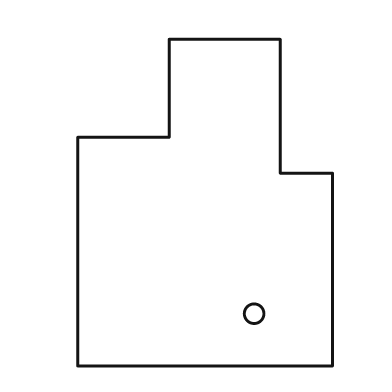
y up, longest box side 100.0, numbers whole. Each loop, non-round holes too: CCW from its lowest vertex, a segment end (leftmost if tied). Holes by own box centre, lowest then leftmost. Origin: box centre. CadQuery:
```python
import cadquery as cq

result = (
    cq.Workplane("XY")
    .moveTo(-39.0, -50.0)
    .lineTo(39.0, -50.0)
    .lineTo(39.0, 9.0)
    .lineTo(23.0, 9.0)
    .lineTo(23.0, 50.0)
    .lineTo(-11.0, 50.0)
    .lineTo(-11.0, 20.0)
    .lineTo(-39.0, 20.0)
    .close()
    .moveTo(15.0, -34.0)
    .circle(3.0)
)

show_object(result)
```